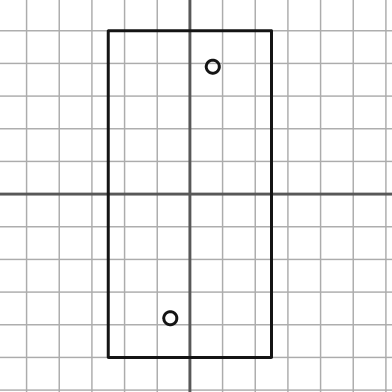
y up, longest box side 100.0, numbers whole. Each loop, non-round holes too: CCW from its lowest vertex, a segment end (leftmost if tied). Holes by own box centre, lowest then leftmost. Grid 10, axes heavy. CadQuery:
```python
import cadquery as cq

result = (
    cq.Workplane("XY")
    .moveTo(-25.0, -50.0)
    .lineTo(25.0, -50.0)
    .lineTo(25.0, 50.0)
    .lineTo(-25.0, 50.0)
    .close()
    .moveTo(-6.0, -38.0)
    .circle(2.0)
    .moveTo(7.0, 39.0)
    .circle(2.0)
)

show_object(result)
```